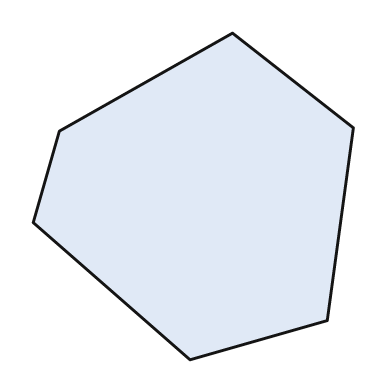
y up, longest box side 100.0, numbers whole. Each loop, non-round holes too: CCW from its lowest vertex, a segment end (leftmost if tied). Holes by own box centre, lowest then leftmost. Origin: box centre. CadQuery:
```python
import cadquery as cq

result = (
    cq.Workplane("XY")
    .moveTo(-1.0, -50.0)
    .lineTo(41.0, -38.0)
    .lineTo(49.0, 21.0)
    .lineTo(12.0, 50.0)
    .lineTo(-41.0, 20.0)
    .lineTo(-49.0, -8.0)
    .close()
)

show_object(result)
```